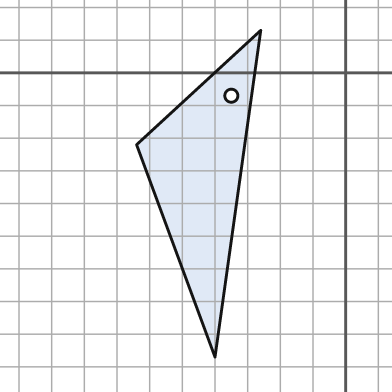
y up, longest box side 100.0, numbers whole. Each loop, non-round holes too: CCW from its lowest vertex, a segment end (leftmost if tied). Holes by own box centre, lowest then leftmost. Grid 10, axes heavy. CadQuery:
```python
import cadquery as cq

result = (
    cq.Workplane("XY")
    .moveTo(-40.0, -87.0)
    .lineTo(-26.0, 13.0)
    .lineTo(-64.0, -22.0)
    .close()
    .moveTo(-35.0, -7.0)
    .circle(2.0)
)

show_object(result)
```